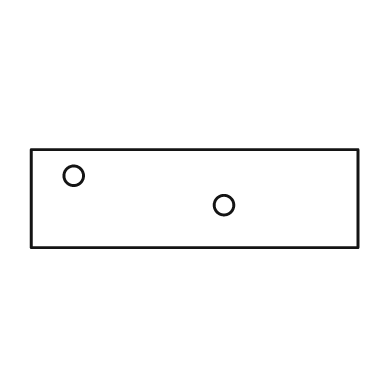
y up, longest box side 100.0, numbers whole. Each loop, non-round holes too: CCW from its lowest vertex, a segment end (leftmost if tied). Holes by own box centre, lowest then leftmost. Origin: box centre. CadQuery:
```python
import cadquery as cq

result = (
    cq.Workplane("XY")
    .moveTo(-50.0, -15.0)
    .lineTo(50.0, -15.0)
    .lineTo(50.0, 15.0)
    .lineTo(-50.0, 15.0)
    .close()
    .moveTo(9.0, -2.0)
    .circle(3.0)
    .moveTo(-37.0, 7.0)
    .circle(3.0)
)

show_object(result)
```